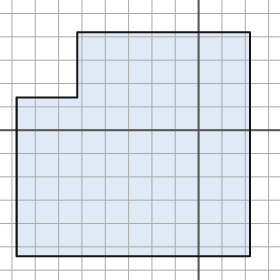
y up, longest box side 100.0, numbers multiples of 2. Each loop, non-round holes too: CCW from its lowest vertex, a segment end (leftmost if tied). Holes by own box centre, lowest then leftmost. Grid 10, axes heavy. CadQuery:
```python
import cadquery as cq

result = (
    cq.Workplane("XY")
    .moveTo(-78.0, -54.0)
    .lineTo(22.0, -54.0)
    .lineTo(22.0, 42.0)
    .lineTo(-52.0, 42.0)
    .lineTo(-52.0, 14.0)
    .lineTo(-78.0, 14.0)
    .close()
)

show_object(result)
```